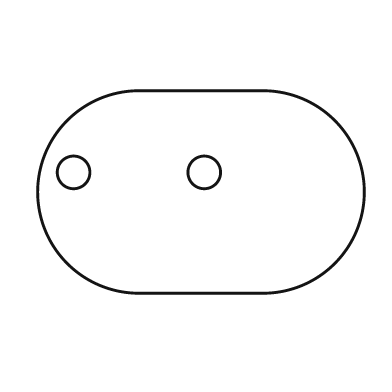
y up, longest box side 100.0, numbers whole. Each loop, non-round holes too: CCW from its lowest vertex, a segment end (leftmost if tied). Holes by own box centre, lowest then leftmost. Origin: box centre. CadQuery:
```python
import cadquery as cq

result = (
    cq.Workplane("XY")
    .moveTo(-19.0, -31.0)
    .lineTo(19.0, -31.0)
    .threePointArc((50.0, 0.0), (19.0, 31.0))
    .lineTo(-19.0, 31.0)
    .threePointArc((-50.0, 0.0), (-19.0, -31.0))
    .close()
    .moveTo(-39.0, 6.0)
    .circle(5.0)
    .moveTo(1.0, 6.0)
    .circle(5.0)
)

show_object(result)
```